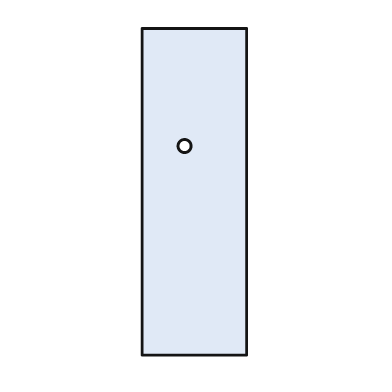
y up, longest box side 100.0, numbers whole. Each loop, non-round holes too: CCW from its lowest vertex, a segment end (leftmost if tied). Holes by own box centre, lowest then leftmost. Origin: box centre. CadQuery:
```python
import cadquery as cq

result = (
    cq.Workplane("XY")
    .moveTo(-16.0, -50.0)
    .lineTo(16.0, -50.0)
    .lineTo(16.0, 50.0)
    .lineTo(-16.0, 50.0)
    .close()
    .moveTo(-3.0, 14.0)
    .circle(2.0)
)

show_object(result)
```